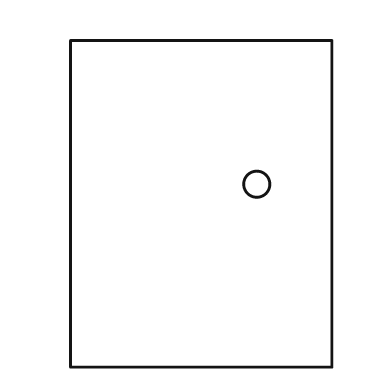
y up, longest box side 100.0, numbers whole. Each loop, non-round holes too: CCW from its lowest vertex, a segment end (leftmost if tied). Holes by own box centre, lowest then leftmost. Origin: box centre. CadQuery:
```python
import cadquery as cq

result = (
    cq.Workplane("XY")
    .moveTo(-40.0, -50.0)
    .lineTo(40.0, -50.0)
    .lineTo(40.0, 50.0)
    .lineTo(-40.0, 50.0)
    .close()
    .moveTo(17.0, 6.0)
    .circle(4.0)
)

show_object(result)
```